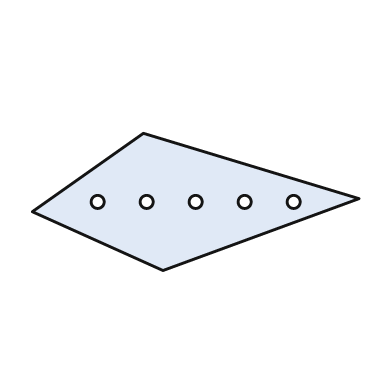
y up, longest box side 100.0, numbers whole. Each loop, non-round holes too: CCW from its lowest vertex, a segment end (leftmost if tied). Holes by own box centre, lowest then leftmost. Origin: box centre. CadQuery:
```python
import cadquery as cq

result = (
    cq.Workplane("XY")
    .moveTo(-10.0, -21.0)
    .lineTo(50.0, 1.0)
    .lineTo(-16.0, 21.0)
    .lineTo(-50.0, -3.0)
    .close()
    .moveTo(-30.0, 0.0)
    .circle(2.0)
    .moveTo(-15.0, 0.0)
    .circle(2.0)
    .moveTo(0.0, 0.0)
    .circle(2.0)
    .moveTo(15.0, 0.0)
    .circle(2.0)
    .moveTo(30.0, 0.0)
    .circle(2.0)
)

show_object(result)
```